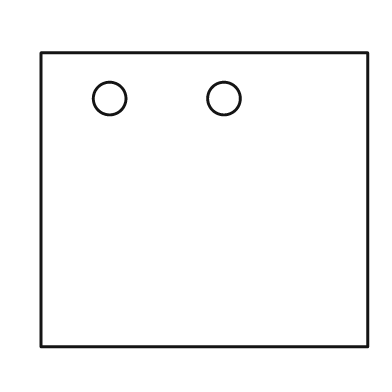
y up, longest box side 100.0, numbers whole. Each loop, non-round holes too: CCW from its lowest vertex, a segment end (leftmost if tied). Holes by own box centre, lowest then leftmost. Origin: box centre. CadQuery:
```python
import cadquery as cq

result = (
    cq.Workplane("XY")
    .moveTo(-50.0, -45.0)
    .lineTo(50.0, -45.0)
    .lineTo(50.0, 45.0)
    .lineTo(-50.0, 45.0)
    .close()
    .moveTo(-29.0, 31.0)
    .circle(5.0)
    .moveTo(6.0, 31.0)
    .circle(5.0)
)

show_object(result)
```